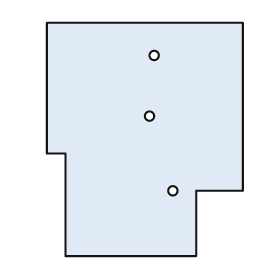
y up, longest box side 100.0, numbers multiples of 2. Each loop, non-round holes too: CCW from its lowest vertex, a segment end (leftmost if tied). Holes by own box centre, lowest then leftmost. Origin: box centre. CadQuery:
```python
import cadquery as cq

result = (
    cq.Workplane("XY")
    .moveTo(-34.0, -50.0)
    .lineTo(22.0, -50.0)
    .lineTo(22.0, -22.0)
    .lineTo(42.0, -22.0)
    .lineTo(42.0, 50.0)
    .lineTo(-42.0, 50.0)
    .lineTo(-42.0, -6.0)
    .lineTo(-34.0, -6.0)
    .close()
    .moveTo(12.0, -22.0)
    .circle(2.0)
    .moveTo(2.0, 10.0)
    .circle(2.0)
    .moveTo(4.0, 36.0)
    .circle(2.0)
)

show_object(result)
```